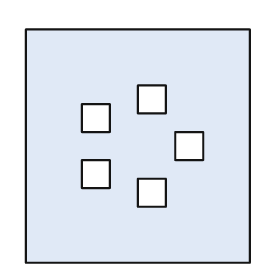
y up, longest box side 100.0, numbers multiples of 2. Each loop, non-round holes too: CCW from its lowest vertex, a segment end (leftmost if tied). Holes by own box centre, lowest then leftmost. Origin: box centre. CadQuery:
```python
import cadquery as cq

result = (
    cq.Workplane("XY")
    .moveTo(-48.0, -50.0)
    .lineTo(48.0, -50.0)
    .lineTo(48.0, 50.0)
    .lineTo(-48.0, 50.0)
    .close()
    .moveTo(0.0, -26.0)
    .lineTo(12.0, -26.0)
    .lineTo(12.0, -14.0)
    .lineTo(0.0, -14.0)
    .close()
    .moveTo(-24.0, -18.0)
    .lineTo(-12.0, -18.0)
    .lineTo(-12.0, -6.0)
    .lineTo(-24.0, -6.0)
    .close()
    .moveTo(16.0, -6.0)
    .lineTo(28.0, -6.0)
    .lineTo(28.0, 6.0)
    .lineTo(16.0, 6.0)
    .close()
    .moveTo(-24.0, 6.0)
    .lineTo(-12.0, 6.0)
    .lineTo(-12.0, 18.0)
    .lineTo(-24.0, 18.0)
    .close()
    .moveTo(0.0, 14.0)
    .lineTo(12.0, 14.0)
    .lineTo(12.0, 26.0)
    .lineTo(0.0, 26.0)
    .close()
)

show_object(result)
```